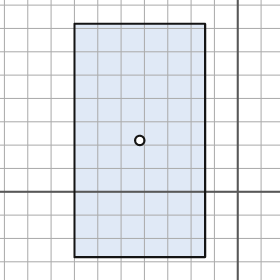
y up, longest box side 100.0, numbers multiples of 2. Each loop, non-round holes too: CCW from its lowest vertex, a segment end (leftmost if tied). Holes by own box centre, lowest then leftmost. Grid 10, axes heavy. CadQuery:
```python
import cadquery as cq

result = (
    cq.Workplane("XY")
    .moveTo(-70.0, -28.0)
    .lineTo(-14.0, -28.0)
    .lineTo(-14.0, 72.0)
    .lineTo(-70.0, 72.0)
    .close()
    .moveTo(-42.0, 22.0)
    .circle(2.0)
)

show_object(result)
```